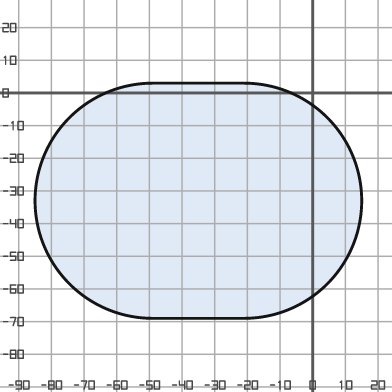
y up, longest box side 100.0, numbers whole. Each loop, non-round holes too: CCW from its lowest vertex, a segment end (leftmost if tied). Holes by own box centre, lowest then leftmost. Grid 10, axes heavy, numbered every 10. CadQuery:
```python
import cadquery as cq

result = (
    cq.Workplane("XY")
    .moveTo(-49.0, -69.0)
    .lineTo(-21.0, -69.0)
    .threePointArc((15.0, -33.0), (-21.0, 3.0))
    .lineTo(-49.0, 3.0)
    .threePointArc((-85.0, -33.0), (-49.0, -69.0))
    .close()
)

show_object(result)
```